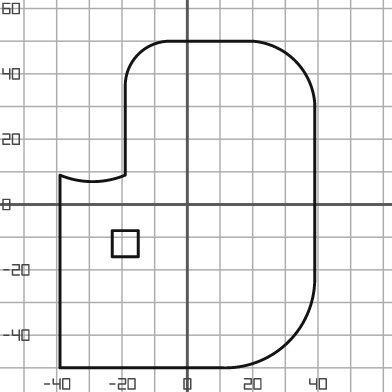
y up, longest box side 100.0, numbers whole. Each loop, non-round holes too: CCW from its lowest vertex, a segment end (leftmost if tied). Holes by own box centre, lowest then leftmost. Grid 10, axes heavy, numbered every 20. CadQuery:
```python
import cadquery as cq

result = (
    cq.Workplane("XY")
    .moveTo(-39.0, -50.0)
    .lineTo(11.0, -50.0)
    .threePointArc((31.0, -42.0), (39.0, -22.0))
    .lineTo(39.0, 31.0)
    .threePointArc((33.0, 44.0), (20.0, 50.0))
    .lineTo(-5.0, 50.0)
    .threePointArc((-15.0, 46.0), (-19.0, 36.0))
    .lineTo(-19.0, 9.0)
    .threePointArc((-29.0, 7.0), (-39.0, 9.0))
    .close()
    .moveTo(-23.0, -16.0)
    .lineTo(-15.0, -16.0)
    .lineTo(-15.0, -8.0)
    .lineTo(-23.0, -8.0)
    .close()
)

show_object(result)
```